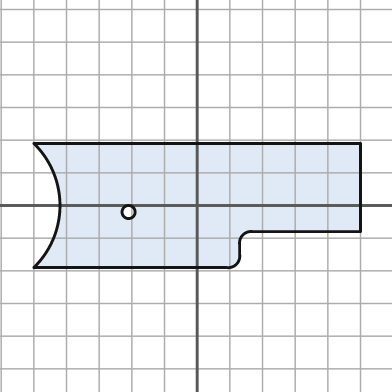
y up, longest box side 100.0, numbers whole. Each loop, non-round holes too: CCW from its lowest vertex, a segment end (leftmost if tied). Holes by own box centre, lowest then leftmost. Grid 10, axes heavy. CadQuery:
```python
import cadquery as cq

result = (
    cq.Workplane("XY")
    .moveTo(-50.0, -19.0)
    .lineTo(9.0, -19.0)
    .threePointArc((12.0, -18.0), (13.0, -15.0))
    .lineTo(13.0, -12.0)
    .threePointArc((14.0, -9.0), (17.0, -8.0))
    .lineTo(50.0, -8.0)
    .lineTo(50.0, 19.0)
    .lineTo(-50.0, 19.0)
    .threePointArc((-42.0, 0.0), (-50.0, -19.0))
    .close()
    .moveTo(-21.0, -2.0)
    .circle(2.0)
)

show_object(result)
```